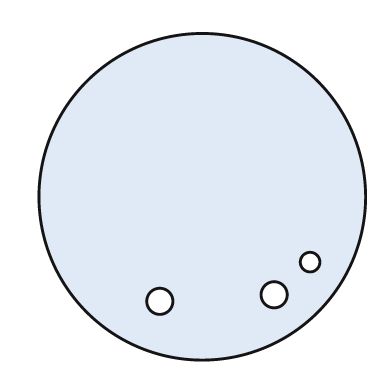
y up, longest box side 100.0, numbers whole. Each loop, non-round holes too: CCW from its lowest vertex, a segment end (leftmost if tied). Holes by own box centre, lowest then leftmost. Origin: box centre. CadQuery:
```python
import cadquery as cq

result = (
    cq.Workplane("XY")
    .moveTo(0.0, 0.0)
    .circle(50.0)
    .moveTo(-13.0, -32.0)
    .circle(4.0)
    .moveTo(22.0, -30.0)
    .circle(4.0)
    .moveTo(33.0, -20.0)
    .circle(3.0)
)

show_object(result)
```